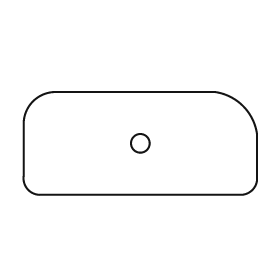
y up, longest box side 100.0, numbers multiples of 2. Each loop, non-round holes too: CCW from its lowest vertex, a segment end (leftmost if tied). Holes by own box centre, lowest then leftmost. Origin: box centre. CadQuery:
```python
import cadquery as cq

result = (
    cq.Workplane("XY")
    .moveTo(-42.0, -22.0)
    .lineTo(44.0, -22.0)
    .threePointArc((48.0, -20.0), (50.0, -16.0))
    .lineTo(50.0, 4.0)
    .threePointArc((44.0, 16.0), (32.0, 22.0))
    .lineTo(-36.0, 22.0)
    .threePointArc((-46.0, 18.0), (-50.0, 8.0))
    .lineTo(-50.0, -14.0)
    .threePointArc((-48.0, -20.0), (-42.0, -22.0))
    .close()
    .moveTo(0.0, 0.0)
    .circle(4.0)
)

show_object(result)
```